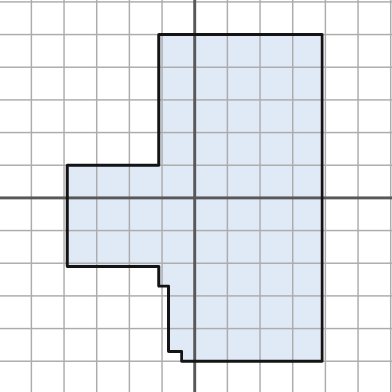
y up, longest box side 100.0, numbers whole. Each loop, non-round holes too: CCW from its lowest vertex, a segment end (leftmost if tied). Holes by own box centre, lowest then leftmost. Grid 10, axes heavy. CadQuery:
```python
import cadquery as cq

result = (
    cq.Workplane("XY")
    .moveTo(-4.0, -50.0)
    .lineTo(39.0, -50.0)
    .lineTo(39.0, 50.0)
    .lineTo(-11.0, 50.0)
    .lineTo(-11.0, 10.0)
    .lineTo(-39.0, 10.0)
    .lineTo(-39.0, -21.0)
    .lineTo(-11.0, -21.0)
    .lineTo(-11.0, -27.0)
    .lineTo(-8.0, -27.0)
    .lineTo(-8.0, -47.0)
    .lineTo(-4.0, -47.0)
    .close()
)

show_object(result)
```